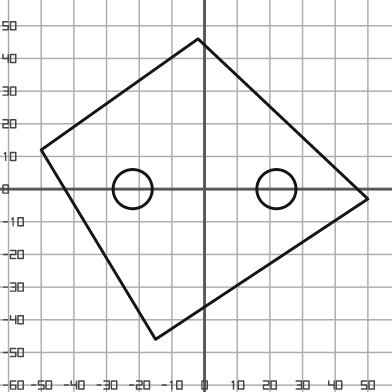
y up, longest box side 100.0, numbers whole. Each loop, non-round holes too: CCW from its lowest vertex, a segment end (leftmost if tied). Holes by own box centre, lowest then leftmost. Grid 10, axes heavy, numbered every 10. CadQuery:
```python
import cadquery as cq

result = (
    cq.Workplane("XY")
    .moveTo(-15.0, -46.0)
    .lineTo(50.0, -3.0)
    .lineTo(-2.0, 46.0)
    .lineTo(-50.0, 12.0)
    .close()
    .moveTo(-22.0, 0.0)
    .circle(6.0)
    .moveTo(22.0, 0.0)
    .circle(6.0)
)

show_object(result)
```